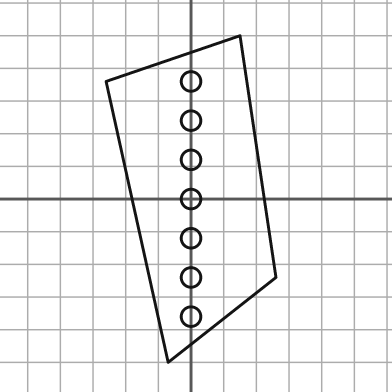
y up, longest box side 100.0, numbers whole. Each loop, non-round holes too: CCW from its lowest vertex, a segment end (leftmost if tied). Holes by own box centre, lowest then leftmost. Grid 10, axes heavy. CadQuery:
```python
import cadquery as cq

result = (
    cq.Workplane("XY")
    .moveTo(-7.0, -50.0)
    .lineTo(26.0, -24.0)
    .lineTo(15.0, 50.0)
    .lineTo(-26.0, 36.0)
    .close()
    .moveTo(0.0, -36.0)
    .circle(3.0)
    .moveTo(0.0, -24.0)
    .circle(3.0)
    .moveTo(0.0, -12.0)
    .circle(3.0)
    .moveTo(0.0, 0.0)
    .circle(3.0)
    .moveTo(0.0, 12.0)
    .circle(3.0)
    .moveTo(0.0, 24.0)
    .circle(3.0)
    .moveTo(0.0, 36.0)
    .circle(3.0)
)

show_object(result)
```